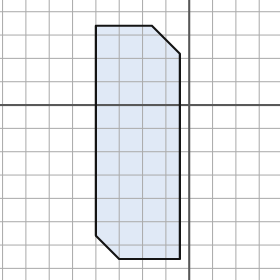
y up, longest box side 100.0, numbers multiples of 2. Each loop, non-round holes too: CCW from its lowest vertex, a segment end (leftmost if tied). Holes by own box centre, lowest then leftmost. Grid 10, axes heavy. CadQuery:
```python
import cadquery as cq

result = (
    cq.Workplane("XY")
    .moveTo(-30.0, -66.0)
    .lineTo(-4.0, -66.0)
    .lineTo(-4.0, 22.0)
    .lineTo(-16.0, 34.0)
    .lineTo(-40.0, 34.0)
    .lineTo(-40.0, -56.0)
    .close()
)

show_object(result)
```